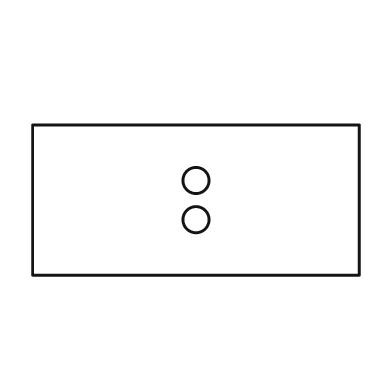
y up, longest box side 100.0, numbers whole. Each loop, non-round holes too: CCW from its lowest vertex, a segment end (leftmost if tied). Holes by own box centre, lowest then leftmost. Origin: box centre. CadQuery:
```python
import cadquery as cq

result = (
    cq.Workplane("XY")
    .moveTo(-50.0, -23.0)
    .lineTo(50.0, -23.0)
    .lineTo(50.0, 23.0)
    .lineTo(-50.0, 23.0)
    .close()
    .moveTo(0.0, -6.0)
    .circle(4.0)
    .moveTo(0.0, 6.0)
    .circle(4.0)
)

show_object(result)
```